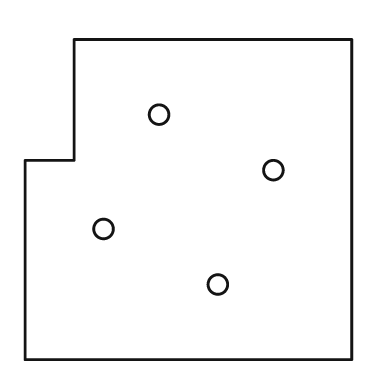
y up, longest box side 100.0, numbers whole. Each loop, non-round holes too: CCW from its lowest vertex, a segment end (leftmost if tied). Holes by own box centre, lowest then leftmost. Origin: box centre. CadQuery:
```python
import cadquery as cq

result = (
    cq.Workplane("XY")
    .moveTo(-50.0, -49.0)
    .lineTo(50.0, -49.0)
    .lineTo(50.0, 49.0)
    .lineTo(-35.0, 49.0)
    .lineTo(-35.0, 12.0)
    .lineTo(-50.0, 12.0)
    .close()
    .moveTo(9.0, -26.0)
    .circle(3.0)
    .moveTo(-26.0, -9.0)
    .circle(3.0)
    .moveTo(26.0, 9.0)
    .circle(3.0)
    .moveTo(-9.0, 26.0)
    .circle(3.0)
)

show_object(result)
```